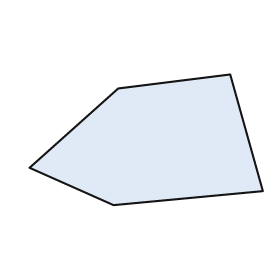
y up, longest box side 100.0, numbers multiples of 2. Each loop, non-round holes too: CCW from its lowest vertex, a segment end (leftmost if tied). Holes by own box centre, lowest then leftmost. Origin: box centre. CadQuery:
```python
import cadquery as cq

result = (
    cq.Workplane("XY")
    .moveTo(-14.0, -28.0)
    .lineTo(50.0, -22.0)
    .lineTo(36.0, 28.0)
    .lineTo(-12.0, 22.0)
    .lineTo(-50.0, -12.0)
    .close()
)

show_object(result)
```